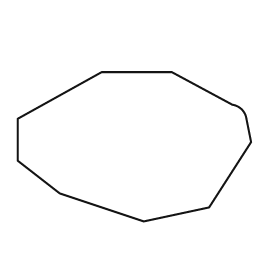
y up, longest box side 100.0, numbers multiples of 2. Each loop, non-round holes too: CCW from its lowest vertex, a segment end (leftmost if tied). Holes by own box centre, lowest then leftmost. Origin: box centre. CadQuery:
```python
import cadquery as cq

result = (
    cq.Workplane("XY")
    .moveTo(4.0, -32.0)
    .lineTo(32.0, -26.0)
    .lineTo(50.0, 2.0)
    .lineTo(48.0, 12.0)
    .threePointArc((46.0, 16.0), (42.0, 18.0))
    .lineTo(16.0, 32.0)
    .lineTo(-14.0, 32.0)
    .lineTo(-50.0, 12.0)
    .lineTo(-50.0, -6.0)
    .lineTo(-32.0, -20.0)
    .close()
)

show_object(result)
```